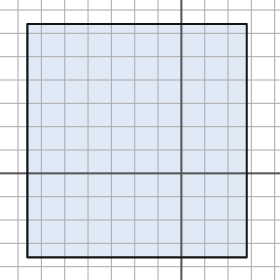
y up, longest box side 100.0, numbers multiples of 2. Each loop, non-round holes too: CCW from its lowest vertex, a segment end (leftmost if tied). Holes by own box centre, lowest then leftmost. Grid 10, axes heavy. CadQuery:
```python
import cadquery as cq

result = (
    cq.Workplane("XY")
    .moveTo(-66.0, -36.0)
    .lineTo(28.0, -36.0)
    .lineTo(28.0, 64.0)
    .lineTo(-66.0, 64.0)
    .close()
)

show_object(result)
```